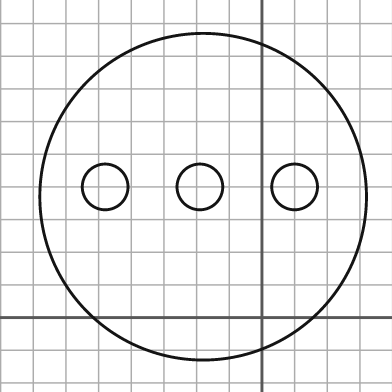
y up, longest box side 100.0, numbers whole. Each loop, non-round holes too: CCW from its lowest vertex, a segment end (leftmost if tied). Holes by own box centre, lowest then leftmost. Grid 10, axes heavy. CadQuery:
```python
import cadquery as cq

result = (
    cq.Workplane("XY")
    .moveTo(-18.0, 37.0)
    .circle(50.0)
    .moveTo(-48.0, 40.0)
    .circle(7.0)
    .moveTo(-19.0, 40.0)
    .circle(7.0)
    .moveTo(10.0, 40.0)
    .circle(7.0)
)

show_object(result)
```